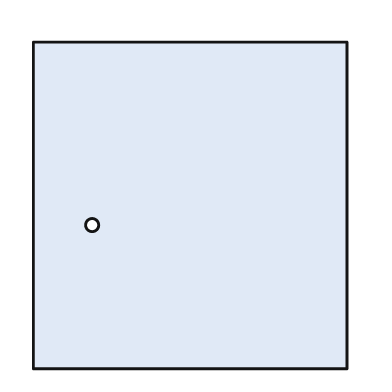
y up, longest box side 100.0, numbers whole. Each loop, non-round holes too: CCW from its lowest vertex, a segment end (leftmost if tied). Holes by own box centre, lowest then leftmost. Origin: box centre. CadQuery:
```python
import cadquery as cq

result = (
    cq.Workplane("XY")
    .moveTo(-48.0, -50.0)
    .lineTo(48.0, -50.0)
    .lineTo(48.0, 50.0)
    .lineTo(-48.0, 50.0)
    .close()
    .moveTo(-30.0, -6.0)
    .circle(2.0)
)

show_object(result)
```